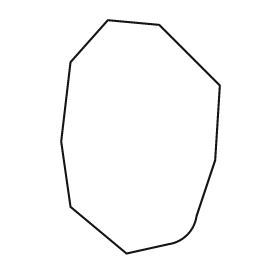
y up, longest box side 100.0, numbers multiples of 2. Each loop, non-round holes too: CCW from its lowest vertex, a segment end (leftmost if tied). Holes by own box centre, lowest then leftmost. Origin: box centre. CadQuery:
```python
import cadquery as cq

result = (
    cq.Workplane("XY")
    .moveTo(-6.0, -50.0)
    .lineTo(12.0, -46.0)
    .threePointArc((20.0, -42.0), (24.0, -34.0))
    .lineTo(32.0, -10.0)
    .lineTo(34.0, 22.0)
    .lineTo(8.0, 48.0)
    .lineTo(-14.0, 50.0)
    .lineTo(-30.0, 32.0)
    .lineTo(-34.0, -2.0)
    .lineTo(-30.0, -30.0)
    .close()
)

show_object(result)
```